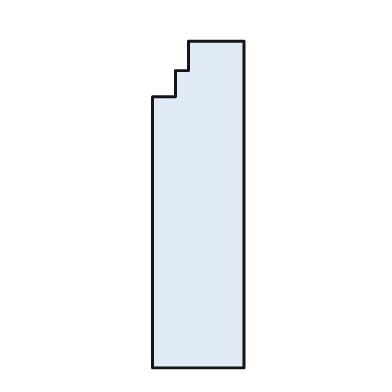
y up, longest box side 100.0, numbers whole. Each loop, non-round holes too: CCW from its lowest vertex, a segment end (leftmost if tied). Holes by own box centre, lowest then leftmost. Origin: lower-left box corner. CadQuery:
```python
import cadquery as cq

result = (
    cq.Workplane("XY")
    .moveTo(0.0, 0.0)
    .lineTo(28.0, 0.0)
    .lineTo(28.0, 100.0)
    .lineTo(11.0, 100.0)
    .lineTo(11.0, 91.0)
    .lineTo(7.0, 91.0)
    .lineTo(7.0, 83.0)
    .lineTo(0.0, 83.0)
    .close()
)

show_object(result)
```